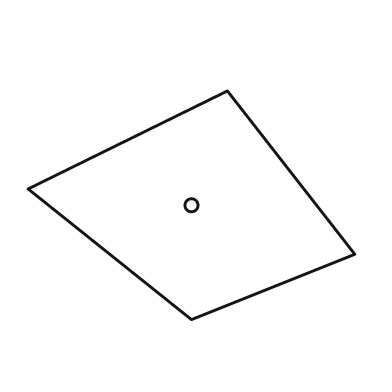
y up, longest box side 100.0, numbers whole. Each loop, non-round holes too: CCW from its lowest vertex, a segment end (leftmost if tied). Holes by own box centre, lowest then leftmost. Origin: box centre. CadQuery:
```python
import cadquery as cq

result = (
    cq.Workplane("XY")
    .moveTo(0.0, -35.0)
    .lineTo(50.0, -15.0)
    .lineTo(11.0, 35.0)
    .lineTo(-50.0, 5.0)
    .close()
    .moveTo(0.0, 0.0)
    .circle(2.0)
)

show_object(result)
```